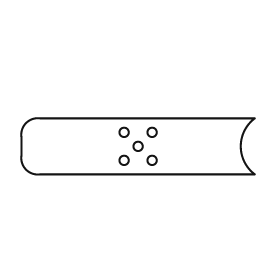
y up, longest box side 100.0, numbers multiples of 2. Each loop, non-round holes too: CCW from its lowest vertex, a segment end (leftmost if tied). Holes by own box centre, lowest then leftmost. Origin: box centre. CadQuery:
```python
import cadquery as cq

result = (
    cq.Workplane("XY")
    .moveTo(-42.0, -12.0)
    .lineTo(50.0, -12.0)
    .threePointArc((44.0, 0.0), (50.0, 12.0))
    .lineTo(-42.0, 12.0)
    .threePointArc((-48.0, 10.0), (-50.0, 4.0))
    .lineTo(-50.0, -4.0)
    .threePointArc((-48.0, -10.0), (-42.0, -12.0))
    .close()
    .moveTo(-6.0, -6.0)
    .circle(2.0)
    .moveTo(6.0, -6.0)
    .circle(2.0)
    .moveTo(0.0, 0.0)
    .circle(2.0)
    .moveTo(-6.0, 6.0)
    .circle(2.0)
    .moveTo(6.0, 6.0)
    .circle(2.0)
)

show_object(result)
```